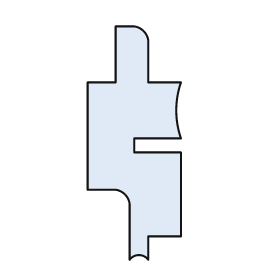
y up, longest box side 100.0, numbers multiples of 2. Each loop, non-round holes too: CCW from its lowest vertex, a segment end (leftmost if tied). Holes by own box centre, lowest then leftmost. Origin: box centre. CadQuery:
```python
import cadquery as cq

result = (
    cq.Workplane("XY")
    .moveTo(-2.0, -50.0)
    .threePointArc((2.0, -48.0), (6.0, -50.0))
    .lineTo(6.0, -40.0)
    .lineTo(20.0, -40.0)
    .lineTo(20.0, -4.0)
    .lineTo(0.0, -4.0)
    .lineTo(0.0, 2.0)
    .lineTo(20.0, 2.0)
    .threePointArc((18.0, 14.0), (20.0, 26.0))
    .lineTo(6.0, 26.0)
    .lineTo(6.0, 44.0)
    .threePointArc((4.0, 48.0), (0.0, 50.0))
    .lineTo(-8.0, 50.0)
    .lineTo(-8.0, 26.0)
    .lineTo(-20.0, 26.0)
    .lineTo(-20.0, -20.0)
    .lineTo(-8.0, -20.0)
    .threePointArc((-4.0, -22.0), (-2.0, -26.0))
    .close()
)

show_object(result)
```